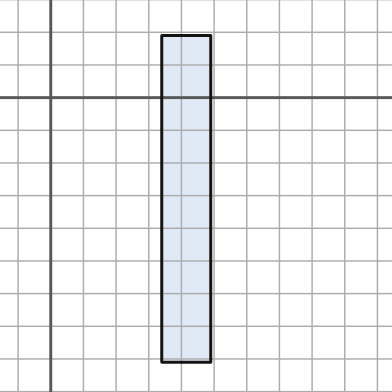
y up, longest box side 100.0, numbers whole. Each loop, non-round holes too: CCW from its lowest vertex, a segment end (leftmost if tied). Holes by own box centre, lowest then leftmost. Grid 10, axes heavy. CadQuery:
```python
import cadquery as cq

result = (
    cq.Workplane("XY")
    .moveTo(34.0, -81.0)
    .lineTo(49.0, -81.0)
    .lineTo(49.0, 19.0)
    .lineTo(34.0, 19.0)
    .close()
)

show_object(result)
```